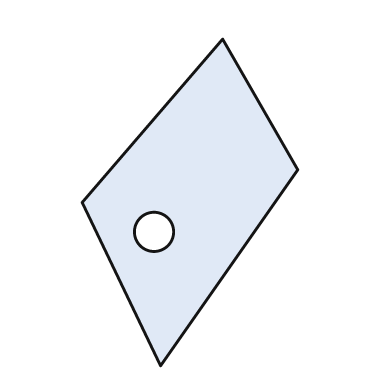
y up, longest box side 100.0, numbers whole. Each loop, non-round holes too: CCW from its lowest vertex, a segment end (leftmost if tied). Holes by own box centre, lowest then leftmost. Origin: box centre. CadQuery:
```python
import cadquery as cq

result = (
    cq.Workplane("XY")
    .moveTo(-9.0, -50.0)
    .lineTo(33.0, 10.0)
    .lineTo(10.0, 50.0)
    .lineTo(-33.0, 0.0)
    .close()
    .moveTo(-11.0, -9.0)
    .circle(6.0)
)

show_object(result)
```